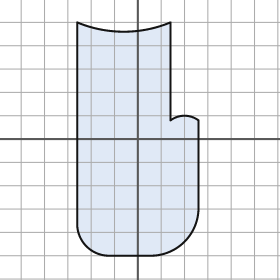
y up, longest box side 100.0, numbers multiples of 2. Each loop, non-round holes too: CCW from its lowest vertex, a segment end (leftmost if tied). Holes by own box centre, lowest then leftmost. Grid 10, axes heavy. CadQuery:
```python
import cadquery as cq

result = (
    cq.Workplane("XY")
    .moveTo(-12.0, -50.0)
    .lineTo(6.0, -50.0)
    .threePointArc((20.0, -44.0), (26.0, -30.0))
    .lineTo(26.0, 8.0)
    .threePointArc((20.0, 10.0), (14.0, 8.0))
    .lineTo(14.0, 50.0)
    .threePointArc((-6.0, 46.0), (-26.0, 50.0))
    .lineTo(-26.0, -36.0)
    .threePointArc((-22.0, -46.0), (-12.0, -50.0))
    .close()
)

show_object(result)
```